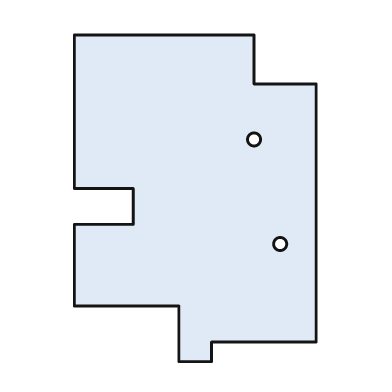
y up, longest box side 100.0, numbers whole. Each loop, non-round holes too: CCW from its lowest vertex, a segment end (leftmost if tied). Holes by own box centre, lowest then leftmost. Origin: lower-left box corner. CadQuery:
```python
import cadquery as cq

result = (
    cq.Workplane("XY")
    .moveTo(32.0, 0.0)
    .lineTo(42.0, 0.0)
    .lineTo(42.0, 6.0)
    .lineTo(74.0, 6.0)
    .lineTo(74.0, 85.0)
    .lineTo(55.0, 85.0)
    .lineTo(55.0, 100.0)
    .lineTo(0.0, 100.0)
    .lineTo(0.0, 53.0)
    .lineTo(18.0, 53.0)
    .lineTo(18.0, 42.0)
    .lineTo(0.0, 42.0)
    .lineTo(0.0, 17.0)
    .lineTo(32.0, 17.0)
    .close()
    .moveTo(63.0, 36.0)
    .circle(2.0)
    .moveTo(55.0, 68.0)
    .circle(2.0)
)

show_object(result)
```